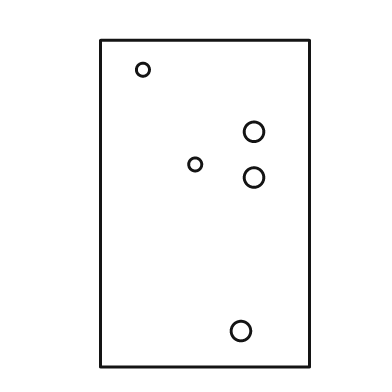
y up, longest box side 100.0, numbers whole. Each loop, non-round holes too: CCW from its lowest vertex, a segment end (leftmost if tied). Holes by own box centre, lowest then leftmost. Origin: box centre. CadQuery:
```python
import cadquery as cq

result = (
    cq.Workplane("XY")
    .moveTo(-32.0, -50.0)
    .lineTo(32.0, -50.0)
    .lineTo(32.0, 50.0)
    .lineTo(-32.0, 50.0)
    .close()
    .moveTo(11.0, -39.0)
    .circle(3.0)
    .moveTo(15.0, 8.0)
    .circle(3.0)
    .moveTo(-3.0, 12.0)
    .circle(2.0)
    .moveTo(15.0, 22.0)
    .circle(3.0)
    .moveTo(-19.0, 41.0)
    .circle(2.0)
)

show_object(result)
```